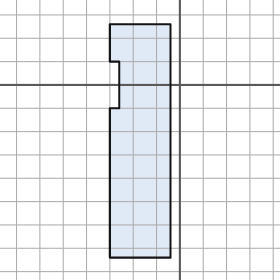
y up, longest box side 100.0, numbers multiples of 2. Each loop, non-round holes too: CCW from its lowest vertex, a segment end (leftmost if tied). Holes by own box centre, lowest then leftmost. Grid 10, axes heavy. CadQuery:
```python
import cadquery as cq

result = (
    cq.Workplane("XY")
    .moveTo(-30.0, -74.0)
    .lineTo(-4.0, -74.0)
    .lineTo(-4.0, 26.0)
    .lineTo(-30.0, 26.0)
    .lineTo(-30.0, 10.0)
    .lineTo(-26.0, 10.0)
    .lineTo(-26.0, -10.0)
    .lineTo(-30.0, -10.0)
    .close()
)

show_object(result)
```